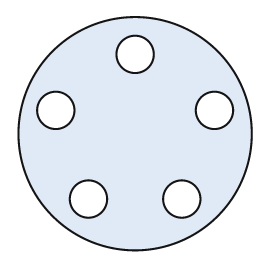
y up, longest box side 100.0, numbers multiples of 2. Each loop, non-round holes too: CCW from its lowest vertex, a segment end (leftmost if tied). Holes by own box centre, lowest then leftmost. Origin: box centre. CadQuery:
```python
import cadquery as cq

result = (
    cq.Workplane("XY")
    .moveTo(0.0, 0.0)
    .circle(50.0)
    .moveTo(-20.0, -28.0)
    .circle(8.0)
    .moveTo(20.0, -28.0)
    .circle(8.0)
    .moveTo(-34.0, 10.0)
    .circle(8.0)
    .moveTo(34.0, 10.0)
    .circle(8.0)
    .moveTo(0.0, 34.0)
    .circle(8.0)
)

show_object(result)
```